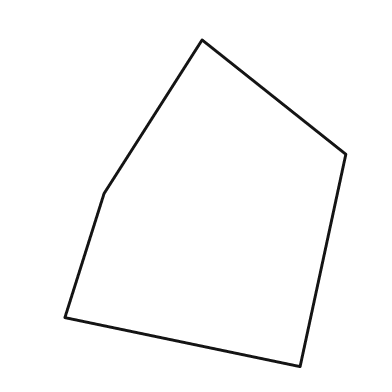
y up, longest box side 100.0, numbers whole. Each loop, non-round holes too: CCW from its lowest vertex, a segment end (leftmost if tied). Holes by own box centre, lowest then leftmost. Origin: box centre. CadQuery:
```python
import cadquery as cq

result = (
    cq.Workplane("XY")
    .moveTo(29.0, -50.0)
    .lineTo(43.0, 15.0)
    .lineTo(-1.0, 50.0)
    .lineTo(-31.0, 3.0)
    .lineTo(-43.0, -35.0)
    .close()
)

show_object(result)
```